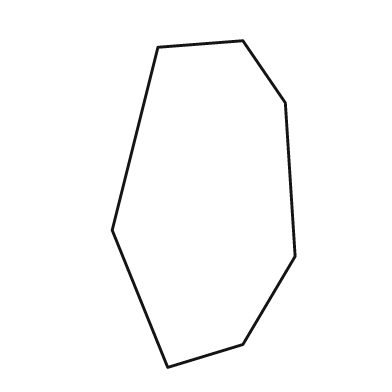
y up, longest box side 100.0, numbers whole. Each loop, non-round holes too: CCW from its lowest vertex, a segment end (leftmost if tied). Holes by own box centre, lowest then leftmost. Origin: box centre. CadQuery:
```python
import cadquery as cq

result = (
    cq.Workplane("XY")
    .moveTo(-11.0, -50.0)
    .lineTo(12.0, -43.0)
    .lineTo(28.0, -16.0)
    .lineTo(25.0, 31.0)
    .lineTo(12.0, 50.0)
    .lineTo(-14.0, 48.0)
    .lineTo(-28.0, -8.0)
    .close()
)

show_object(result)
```